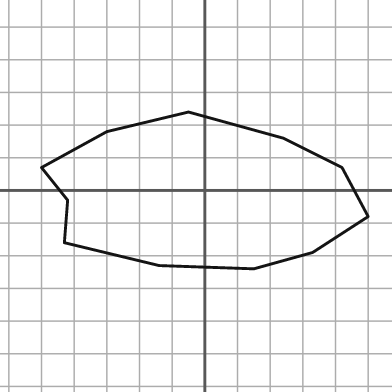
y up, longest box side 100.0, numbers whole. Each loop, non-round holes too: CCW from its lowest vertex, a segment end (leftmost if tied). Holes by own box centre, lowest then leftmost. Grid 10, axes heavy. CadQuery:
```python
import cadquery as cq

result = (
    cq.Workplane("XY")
    .moveTo(15.0, -24.0)
    .lineTo(33.0, -19.0)
    .lineTo(50.0, -8.0)
    .lineTo(42.0, 7.0)
    .lineTo(24.0, 16.0)
    .lineTo(-5.0, 24.0)
    .lineTo(-30.0, 18.0)
    .lineTo(-50.0, 7.0)
    .lineTo(-42.0, -3.0)
    .lineTo(-43.0, -16.0)
    .lineTo(-14.0, -23.0)
    .close()
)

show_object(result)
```